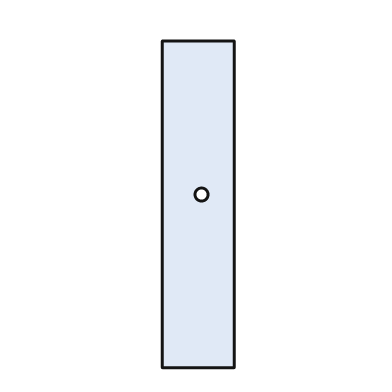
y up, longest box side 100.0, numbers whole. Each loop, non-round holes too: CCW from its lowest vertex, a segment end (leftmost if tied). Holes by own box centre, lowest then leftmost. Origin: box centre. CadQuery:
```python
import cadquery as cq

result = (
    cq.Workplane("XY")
    .moveTo(-11.0, -50.0)
    .lineTo(11.0, -50.0)
    .lineTo(11.0, 50.0)
    .lineTo(-11.0, 50.0)
    .close()
    .moveTo(1.0, 3.0)
    .circle(2.0)
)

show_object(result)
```